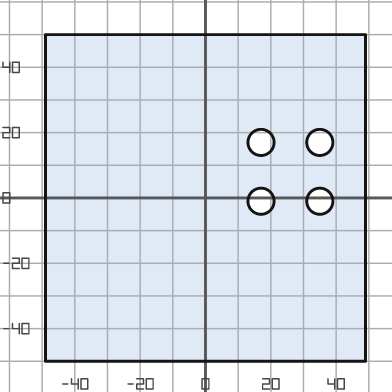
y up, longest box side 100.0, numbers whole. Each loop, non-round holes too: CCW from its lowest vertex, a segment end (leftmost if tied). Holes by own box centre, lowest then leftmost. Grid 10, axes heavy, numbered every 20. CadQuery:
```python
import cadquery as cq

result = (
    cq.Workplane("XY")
    .moveTo(-49.0, -50.0)
    .lineTo(49.0, -50.0)
    .lineTo(49.0, 50.0)
    .lineTo(-49.0, 50.0)
    .close()
    .moveTo(17.0, -1.0)
    .circle(4.0)
    .moveTo(35.0, -1.0)
    .circle(4.0)
    .moveTo(17.0, 17.0)
    .circle(4.0)
    .moveTo(35.0, 17.0)
    .circle(4.0)
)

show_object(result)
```